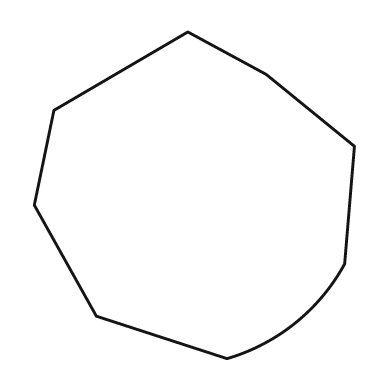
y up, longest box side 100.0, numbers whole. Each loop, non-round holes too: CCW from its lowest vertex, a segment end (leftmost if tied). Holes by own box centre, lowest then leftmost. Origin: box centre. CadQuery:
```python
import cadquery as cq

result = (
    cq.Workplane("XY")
    .moveTo(10.0, -50.0)
    .threePointArc((31.0, -39.0), (46.0, -21.0))
    .lineTo(49.0, 15.0)
    .lineTo(22.0, 37.0)
    .lineTo(-2.0, 50.0)
    .lineTo(-43.0, 26.0)
    .lineTo(-49.0, -3.0)
    .lineTo(-30.0, -37.0)
    .close()
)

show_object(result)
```